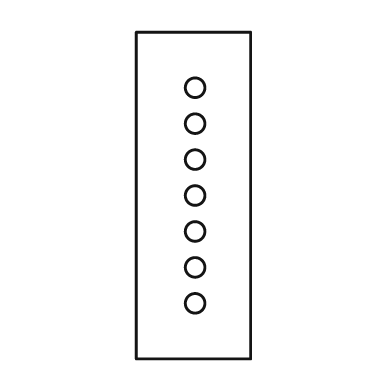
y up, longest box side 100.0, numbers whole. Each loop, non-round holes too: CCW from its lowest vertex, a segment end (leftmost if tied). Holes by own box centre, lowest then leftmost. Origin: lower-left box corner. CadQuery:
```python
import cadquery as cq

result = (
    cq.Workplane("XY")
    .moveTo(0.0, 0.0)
    .lineTo(35.0, 0.0)
    .lineTo(35.0, 100.0)
    .lineTo(0.0, 100.0)
    .close()
    .moveTo(18.0, 17.0)
    .circle(3.0)
    .moveTo(18.0, 28.0)
    .circle(3.0)
    .moveTo(18.0, 39.0)
    .circle(3.0)
    .moveTo(18.0, 50.0)
    .circle(3.0)
    .moveTo(18.0, 61.0)
    .circle(3.0)
    .moveTo(18.0, 72.0)
    .circle(3.0)
    .moveTo(18.0, 83.0)
    .circle(3.0)
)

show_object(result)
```